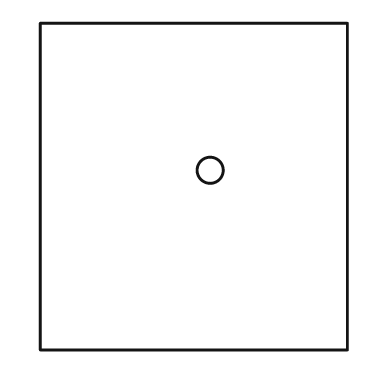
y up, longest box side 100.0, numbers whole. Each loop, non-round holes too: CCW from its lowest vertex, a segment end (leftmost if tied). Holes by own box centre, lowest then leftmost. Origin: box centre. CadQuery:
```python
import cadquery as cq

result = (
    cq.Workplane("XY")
    .moveTo(-47.0, -50.0)
    .lineTo(47.0, -50.0)
    .lineTo(47.0, 50.0)
    .lineTo(-47.0, 50.0)
    .close()
    .moveTo(5.0, 5.0)
    .circle(4.0)
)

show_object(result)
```